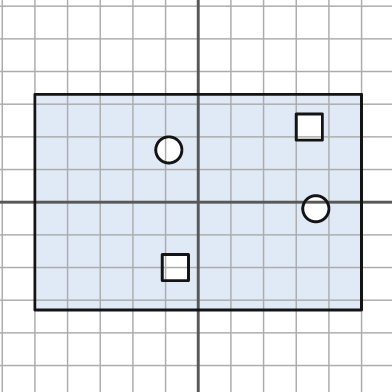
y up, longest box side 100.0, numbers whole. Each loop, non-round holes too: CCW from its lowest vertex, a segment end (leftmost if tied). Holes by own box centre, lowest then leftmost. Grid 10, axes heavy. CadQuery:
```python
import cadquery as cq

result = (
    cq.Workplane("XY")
    .moveTo(-50.0, -33.0)
    .lineTo(50.0, -33.0)
    .lineTo(50.0, 33.0)
    .lineTo(-50.0, 33.0)
    .close()
    .moveTo(-11.0, -24.0)
    .lineTo(-3.0, -24.0)
    .lineTo(-3.0, -16.0)
    .lineTo(-11.0, -16.0)
    .close()
    .moveTo(36.0, -2.0)
    .circle(4.0)
    .moveTo(-9.0, 16.0)
    .circle(4.0)
    .moveTo(30.0, 19.0)
    .lineTo(38.0, 19.0)
    .lineTo(38.0, 27.0)
    .lineTo(30.0, 27.0)
    .close()
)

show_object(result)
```